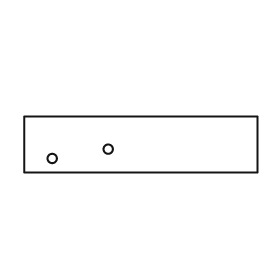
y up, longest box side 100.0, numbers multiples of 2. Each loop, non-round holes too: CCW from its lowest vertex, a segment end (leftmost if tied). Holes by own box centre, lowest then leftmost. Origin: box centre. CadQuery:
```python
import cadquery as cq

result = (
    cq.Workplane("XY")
    .moveTo(-50.0, -12.0)
    .lineTo(50.0, -12.0)
    .lineTo(50.0, 12.0)
    .lineTo(-50.0, 12.0)
    .close()
    .moveTo(-38.0, -6.0)
    .circle(2.0)
    .moveTo(-14.0, -2.0)
    .circle(2.0)
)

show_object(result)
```